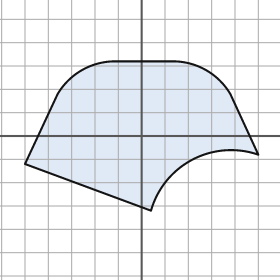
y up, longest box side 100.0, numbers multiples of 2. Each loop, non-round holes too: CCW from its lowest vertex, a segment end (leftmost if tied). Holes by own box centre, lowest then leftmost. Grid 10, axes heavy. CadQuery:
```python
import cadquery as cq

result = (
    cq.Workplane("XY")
    .moveTo(4.0, -32.0)
    .threePointArc((22.0, -10.0), (50.0, -8.0))
    .lineTo(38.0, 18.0)
    .threePointArc((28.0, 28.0), (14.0, 32.0))
    .lineTo(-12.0, 32.0)
    .threePointArc((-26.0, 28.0), (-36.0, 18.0))
    .lineTo(-50.0, -12.0)
    .close()
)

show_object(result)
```